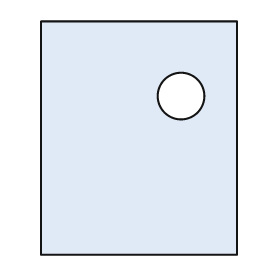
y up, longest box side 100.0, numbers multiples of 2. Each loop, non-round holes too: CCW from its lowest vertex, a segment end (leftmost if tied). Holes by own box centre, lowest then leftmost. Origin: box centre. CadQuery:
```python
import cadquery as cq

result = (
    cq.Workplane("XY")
    .moveTo(-42.0, -50.0)
    .lineTo(42.0, -50.0)
    .lineTo(42.0, 50.0)
    .lineTo(-42.0, 50.0)
    .close()
    .moveTo(18.0, 18.0)
    .circle(10.0)
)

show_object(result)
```